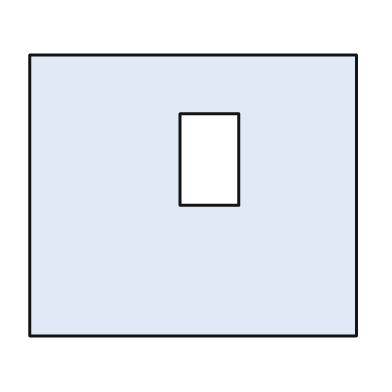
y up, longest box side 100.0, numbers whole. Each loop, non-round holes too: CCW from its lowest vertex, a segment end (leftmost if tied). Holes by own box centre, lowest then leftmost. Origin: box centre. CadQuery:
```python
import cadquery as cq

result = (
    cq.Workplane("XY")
    .moveTo(-50.0, -43.0)
    .lineTo(50.0, -43.0)
    .lineTo(50.0, 43.0)
    .lineTo(-50.0, 43.0)
    .close()
    .moveTo(-4.0, -3.0)
    .lineTo(14.0, -3.0)
    .lineTo(14.0, 25.0)
    .lineTo(-4.0, 25.0)
    .close()
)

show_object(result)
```